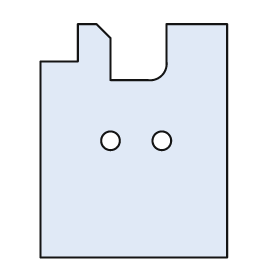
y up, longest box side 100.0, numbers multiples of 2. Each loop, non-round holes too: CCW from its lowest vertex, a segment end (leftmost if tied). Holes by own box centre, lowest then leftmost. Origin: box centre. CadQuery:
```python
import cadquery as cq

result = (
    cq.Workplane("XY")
    .moveTo(-40.0, -50.0)
    .lineTo(40.0, -50.0)
    .lineTo(40.0, 50.0)
    .lineTo(14.0, 50.0)
    .lineTo(14.0, 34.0)
    .threePointArc((12.0, 28.0), (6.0, 26.0))
    .lineTo(-10.0, 26.0)
    .lineTo(-10.0, 44.0)
    .lineTo(-16.0, 50.0)
    .lineTo(-24.0, 50.0)
    .lineTo(-24.0, 34.0)
    .lineTo(-40.0, 34.0)
    .close()
    .moveTo(-10.0, 0.0)
    .circle(4.0)
    .moveTo(12.0, 0.0)
    .circle(4.0)
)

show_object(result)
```